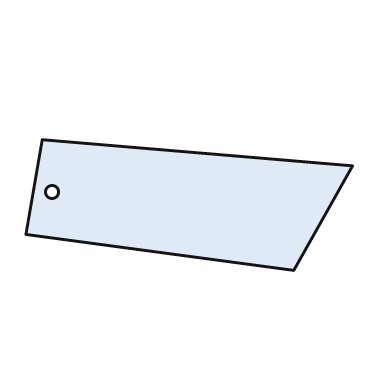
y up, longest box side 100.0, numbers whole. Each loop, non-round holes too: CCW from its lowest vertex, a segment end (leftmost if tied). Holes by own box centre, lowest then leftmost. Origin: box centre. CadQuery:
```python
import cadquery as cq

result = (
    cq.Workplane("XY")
    .moveTo(32.0, -20.0)
    .lineTo(50.0, 12.0)
    .lineTo(-45.0, 20.0)
    .lineTo(-50.0, -9.0)
    .close()
    .moveTo(-42.0, 4.0)
    .circle(2.0)
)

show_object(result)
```